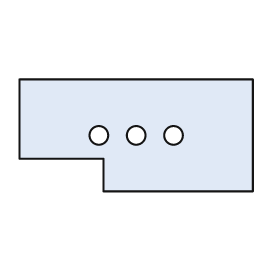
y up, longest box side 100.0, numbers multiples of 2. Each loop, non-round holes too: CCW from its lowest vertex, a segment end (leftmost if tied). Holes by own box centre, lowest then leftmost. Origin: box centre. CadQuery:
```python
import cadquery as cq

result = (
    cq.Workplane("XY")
    .moveTo(-14.0, -24.0)
    .lineTo(50.0, -24.0)
    .lineTo(50.0, 24.0)
    .lineTo(-50.0, 24.0)
    .lineTo(-50.0, -10.0)
    .lineTo(-14.0, -10.0)
    .close()
    .moveTo(-16.0, 0.0)
    .circle(4.0)
    .moveTo(0.0, 0.0)
    .circle(4.0)
    .moveTo(16.0, 0.0)
    .circle(4.0)
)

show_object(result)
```